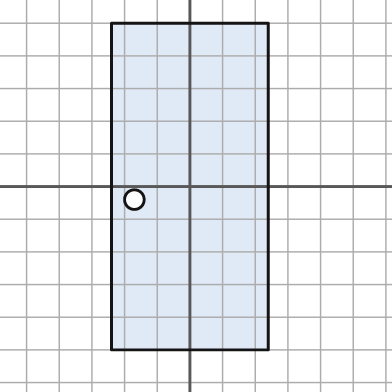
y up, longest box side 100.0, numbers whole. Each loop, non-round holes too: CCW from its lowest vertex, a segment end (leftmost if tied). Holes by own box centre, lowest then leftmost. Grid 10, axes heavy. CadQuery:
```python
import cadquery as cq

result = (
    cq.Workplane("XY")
    .moveTo(-24.0, -50.0)
    .lineTo(24.0, -50.0)
    .lineTo(24.0, 50.0)
    .lineTo(-24.0, 50.0)
    .close()
    .moveTo(-17.0, -4.0)
    .circle(3.0)
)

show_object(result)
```